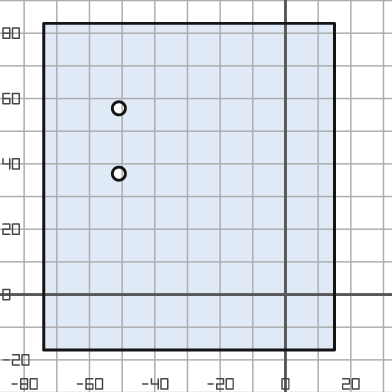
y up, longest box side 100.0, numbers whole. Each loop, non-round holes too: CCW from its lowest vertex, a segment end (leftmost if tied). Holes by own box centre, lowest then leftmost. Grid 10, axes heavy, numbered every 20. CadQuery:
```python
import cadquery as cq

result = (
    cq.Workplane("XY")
    .moveTo(-74.0, -17.0)
    .lineTo(15.0, -17.0)
    .lineTo(15.0, 83.0)
    .lineTo(-74.0, 83.0)
    .close()
    .moveTo(-51.0, 37.0)
    .circle(2.0)
    .moveTo(-51.0, 57.0)
    .circle(2.0)
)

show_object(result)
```